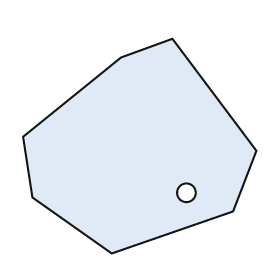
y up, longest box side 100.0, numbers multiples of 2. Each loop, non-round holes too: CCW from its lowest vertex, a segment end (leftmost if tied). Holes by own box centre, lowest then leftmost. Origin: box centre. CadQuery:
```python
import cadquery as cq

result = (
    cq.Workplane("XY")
    .moveTo(-12.0, -46.0)
    .lineTo(40.0, -28.0)
    .lineTo(50.0, -2.0)
    .lineTo(14.0, 46.0)
    .lineTo(-8.0, 38.0)
    .lineTo(-50.0, 4.0)
    .lineTo(-46.0, -22.0)
    .close()
    .moveTo(20.0, -20.0)
    .circle(4.0)
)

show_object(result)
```